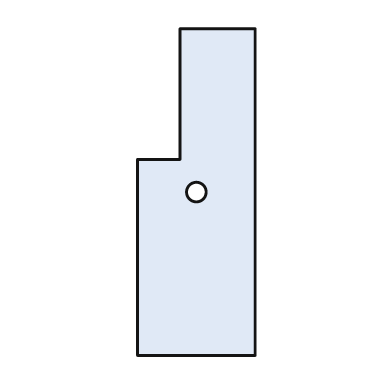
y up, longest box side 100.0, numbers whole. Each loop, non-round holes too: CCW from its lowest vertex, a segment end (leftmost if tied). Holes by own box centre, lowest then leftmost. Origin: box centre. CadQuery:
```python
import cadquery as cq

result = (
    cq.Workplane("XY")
    .moveTo(-18.0, -50.0)
    .lineTo(18.0, -50.0)
    .lineTo(18.0, 50.0)
    .lineTo(-5.0, 50.0)
    .lineTo(-5.0, 10.0)
    .lineTo(-18.0, 10.0)
    .close()
    .moveTo(0.0, 0.0)
    .circle(3.0)
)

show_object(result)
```